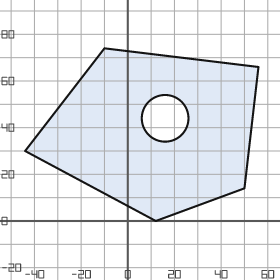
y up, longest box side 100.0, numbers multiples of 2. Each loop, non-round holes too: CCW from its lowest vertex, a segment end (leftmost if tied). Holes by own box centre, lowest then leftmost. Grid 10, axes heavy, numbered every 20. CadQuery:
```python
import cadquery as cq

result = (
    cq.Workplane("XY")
    .moveTo(12.0, 0.0)
    .lineTo(50.0, 14.0)
    .lineTo(56.0, 66.0)
    .lineTo(-10.0, 74.0)
    .lineTo(-44.0, 30.0)
    .close()
    .moveTo(16.0, 44.0)
    .circle(10.0)
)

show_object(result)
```